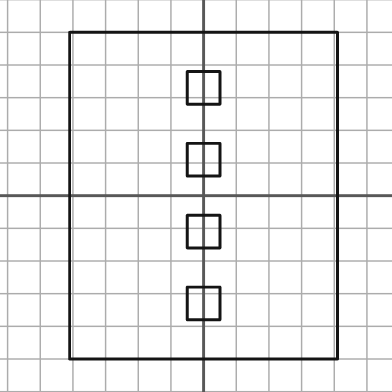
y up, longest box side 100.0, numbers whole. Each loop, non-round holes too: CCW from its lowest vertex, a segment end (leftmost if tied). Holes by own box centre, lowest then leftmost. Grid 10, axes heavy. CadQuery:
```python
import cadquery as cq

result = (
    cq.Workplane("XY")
    .moveTo(-41.0, -50.0)
    .lineTo(41.0, -50.0)
    .lineTo(41.0, 50.0)
    .lineTo(-41.0, 50.0)
    .close()
    .moveTo(-5.0, -38.0)
    .lineTo(5.0, -38.0)
    .lineTo(5.0, -28.0)
    .lineTo(-5.0, -28.0)
    .close()
    .moveTo(-5.0, -16.0)
    .lineTo(5.0, -16.0)
    .lineTo(5.0, -6.0)
    .lineTo(-5.0, -6.0)
    .close()
    .moveTo(-5.0, 6.0)
    .lineTo(5.0, 6.0)
    .lineTo(5.0, 16.0)
    .lineTo(-5.0, 16.0)
    .close()
    .moveTo(-5.0, 28.0)
    .lineTo(5.0, 28.0)
    .lineTo(5.0, 38.0)
    .lineTo(-5.0, 38.0)
    .close()
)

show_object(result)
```